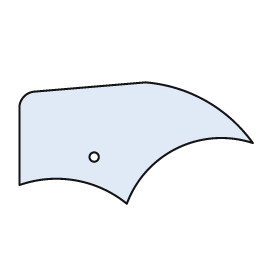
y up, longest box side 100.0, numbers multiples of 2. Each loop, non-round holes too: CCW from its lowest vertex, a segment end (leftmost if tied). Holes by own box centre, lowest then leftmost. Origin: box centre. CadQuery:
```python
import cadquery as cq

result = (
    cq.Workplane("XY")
    .moveTo(-4.0, -26.0)
    .threePointArc((18.0, -2.0), (50.0, 0.0))
    .threePointArc((30.0, 18.0), (4.0, 26.0))
    .lineTo(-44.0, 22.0)
    .threePointArc((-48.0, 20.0), (-50.0, 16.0))
    .lineTo(-50.0, -18.0)
    .threePointArc((-26.0, -16.0), (-4.0, -26.0))
    .close()
    .moveTo(-18.0, -6.0)
    .circle(2.0)
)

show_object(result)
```